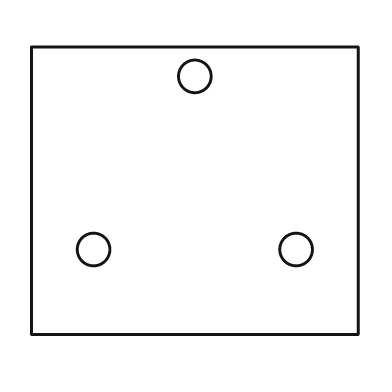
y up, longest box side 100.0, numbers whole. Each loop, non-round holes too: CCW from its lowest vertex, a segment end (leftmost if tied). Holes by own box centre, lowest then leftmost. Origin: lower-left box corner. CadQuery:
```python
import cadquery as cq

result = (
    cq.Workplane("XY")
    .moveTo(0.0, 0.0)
    .lineTo(100.0, 0.0)
    .lineTo(100.0, 88.0)
    .lineTo(0.0, 88.0)
    .close()
    .moveTo(19.0, 26.0)
    .circle(5.0)
    .moveTo(81.0, 26.0)
    .circle(5.0)
    .moveTo(50.0, 79.0)
    .circle(5.0)
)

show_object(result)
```